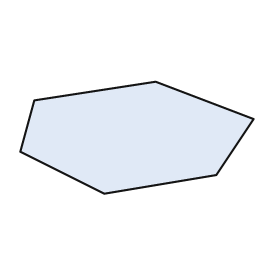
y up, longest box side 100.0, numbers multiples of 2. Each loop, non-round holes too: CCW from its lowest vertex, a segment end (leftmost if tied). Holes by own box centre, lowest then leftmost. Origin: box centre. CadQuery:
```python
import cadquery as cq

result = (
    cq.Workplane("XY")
    .moveTo(-14.0, -24.0)
    .lineTo(34.0, -16.0)
    .lineTo(50.0, 8.0)
    .lineTo(8.0, 24.0)
    .lineTo(-44.0, 16.0)
    .lineTo(-50.0, -6.0)
    .close()
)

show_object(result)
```